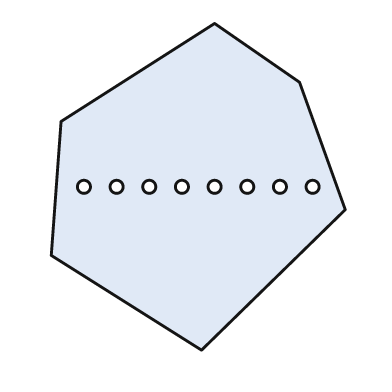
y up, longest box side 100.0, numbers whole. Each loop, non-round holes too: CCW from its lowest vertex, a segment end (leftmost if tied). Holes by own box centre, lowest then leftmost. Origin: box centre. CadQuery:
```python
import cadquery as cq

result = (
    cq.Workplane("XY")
    .moveTo(1.0, -50.0)
    .lineTo(45.0, -7.0)
    .lineTo(31.0, 32.0)
    .lineTo(5.0, 50.0)
    .lineTo(-42.0, 20.0)
    .lineTo(-45.0, -21.0)
    .close()
    .moveTo(-35.0, 0.0)
    .circle(2.0)
    .moveTo(-25.0, 0.0)
    .circle(2.0)
    .moveTo(-15.0, 0.0)
    .circle(2.0)
    .moveTo(-5.0, 0.0)
    .circle(2.0)
    .moveTo(5.0, 0.0)
    .circle(2.0)
    .moveTo(15.0, 0.0)
    .circle(2.0)
    .moveTo(25.0, 0.0)
    .circle(2.0)
    .moveTo(35.0, 0.0)
    .circle(2.0)
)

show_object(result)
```